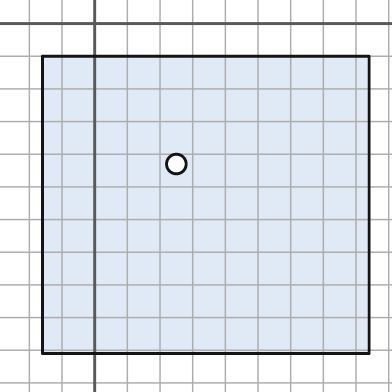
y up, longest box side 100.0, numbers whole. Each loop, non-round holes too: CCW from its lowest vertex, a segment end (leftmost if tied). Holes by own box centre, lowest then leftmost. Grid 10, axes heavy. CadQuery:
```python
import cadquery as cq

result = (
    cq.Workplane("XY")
    .moveTo(-16.0, -101.0)
    .lineTo(84.0, -101.0)
    .lineTo(84.0, -10.0)
    .lineTo(-16.0, -10.0)
    .close()
    .moveTo(25.0, -43.0)
    .circle(3.0)
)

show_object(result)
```